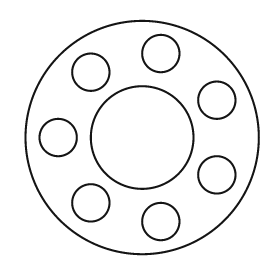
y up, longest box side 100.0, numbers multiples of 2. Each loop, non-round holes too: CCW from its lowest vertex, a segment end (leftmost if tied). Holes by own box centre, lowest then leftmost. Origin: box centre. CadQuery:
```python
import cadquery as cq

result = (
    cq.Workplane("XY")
    .moveTo(0.0, 0.0)
    .circle(50.0)
    .moveTo(8.0, -36.0)
    .circle(8.0)
    .moveTo(-22.0, -28.0)
    .circle(8.0)
    .moveTo(32.0, -16.0)
    .circle(8.0)
    .moveTo(-36.0, 0.0)
    .circle(8.0)
    .moveTo(0.0, 0.0)
    .circle(22.0)
    .moveTo(32.0, 16.0)
    .circle(8.0)
    .moveTo(-22.0, 28.0)
    .circle(8.0)
    .moveTo(8.0, 36.0)
    .circle(8.0)
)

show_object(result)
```